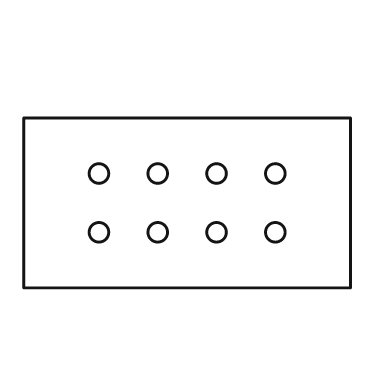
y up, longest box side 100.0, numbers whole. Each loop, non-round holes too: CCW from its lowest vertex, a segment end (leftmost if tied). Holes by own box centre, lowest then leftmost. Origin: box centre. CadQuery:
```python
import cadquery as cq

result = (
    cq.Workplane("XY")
    .moveTo(-50.0, -26.0)
    .lineTo(50.0, -26.0)
    .lineTo(50.0, 26.0)
    .lineTo(-50.0, 26.0)
    .close()
    .moveTo(-27.0, -9.0)
    .circle(3.0)
    .moveTo(-9.0, -9.0)
    .circle(3.0)
    .moveTo(9.0, -9.0)
    .circle(3.0)
    .moveTo(27.0, -9.0)
    .circle(3.0)
    .moveTo(-27.0, 9.0)
    .circle(3.0)
    .moveTo(-9.0, 9.0)
    .circle(3.0)
    .moveTo(9.0, 9.0)
    .circle(3.0)
    .moveTo(27.0, 9.0)
    .circle(3.0)
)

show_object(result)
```